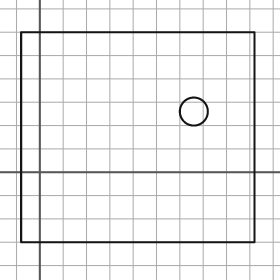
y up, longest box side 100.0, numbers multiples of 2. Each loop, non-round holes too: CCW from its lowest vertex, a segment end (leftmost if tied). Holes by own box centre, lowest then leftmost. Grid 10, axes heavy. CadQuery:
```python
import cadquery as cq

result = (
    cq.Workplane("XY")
    .moveTo(-8.0, -30.0)
    .lineTo(92.0, -30.0)
    .lineTo(92.0, 60.0)
    .lineTo(-8.0, 60.0)
    .close()
    .moveTo(66.0, 26.0)
    .circle(6.0)
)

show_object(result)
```